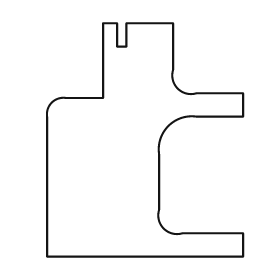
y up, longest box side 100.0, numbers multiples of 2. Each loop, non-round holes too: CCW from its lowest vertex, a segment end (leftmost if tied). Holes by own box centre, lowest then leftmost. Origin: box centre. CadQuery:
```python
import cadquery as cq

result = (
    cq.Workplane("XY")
    .moveTo(-42.0, -50.0)
    .lineTo(42.0, -50.0)
    .lineTo(42.0, -40.0)
    .lineTo(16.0, -40.0)
    .threePointArc((8.0, -38.0), (6.0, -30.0))
    .lineTo(6.0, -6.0)
    .threePointArc((10.0, 6.0), (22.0, 10.0))
    .lineTo(42.0, 10.0)
    .lineTo(42.0, 20.0)
    .lineTo(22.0, 20.0)
    .threePointArc((14.0, 22.0), (12.0, 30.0))
    .lineTo(12.0, 50.0)
    .lineTo(-8.0, 50.0)
    .lineTo(-8.0, 40.0)
    .lineTo(-12.0, 40.0)
    .lineTo(-12.0, 50.0)
    .lineTo(-18.0, 50.0)
    .lineTo(-18.0, 18.0)
    .lineTo(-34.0, 18.0)
    .threePointArc((-40.0, 16.0), (-42.0, 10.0))
    .close()
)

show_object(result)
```